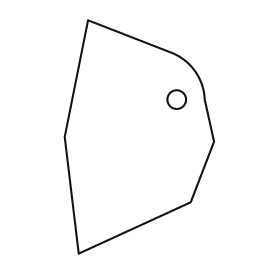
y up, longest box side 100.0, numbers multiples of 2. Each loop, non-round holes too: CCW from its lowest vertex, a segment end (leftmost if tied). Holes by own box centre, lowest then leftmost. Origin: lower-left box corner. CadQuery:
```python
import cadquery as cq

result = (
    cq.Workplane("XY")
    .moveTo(6.0, 0.0)
    .lineTo(54.0, 22.0)
    .lineTo(64.0, 48.0)
    .lineTo(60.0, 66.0)
    .threePointArc((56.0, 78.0), (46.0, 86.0))
    .lineTo(10.0, 100.0)
    .lineTo(0.0, 50.0)
    .close()
    .moveTo(48.0, 66.0)
    .circle(4.0)
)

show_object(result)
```